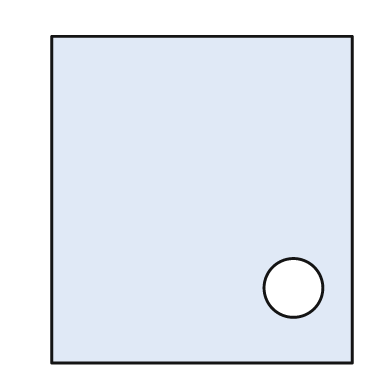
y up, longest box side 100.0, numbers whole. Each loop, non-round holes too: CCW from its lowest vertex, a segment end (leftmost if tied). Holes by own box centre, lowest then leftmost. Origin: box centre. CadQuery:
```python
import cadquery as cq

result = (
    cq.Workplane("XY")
    .moveTo(-46.0, -50.0)
    .lineTo(46.0, -50.0)
    .lineTo(46.0, 50.0)
    .lineTo(-46.0, 50.0)
    .close()
    .moveTo(28.0, -27.0)
    .circle(9.0)
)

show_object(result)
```